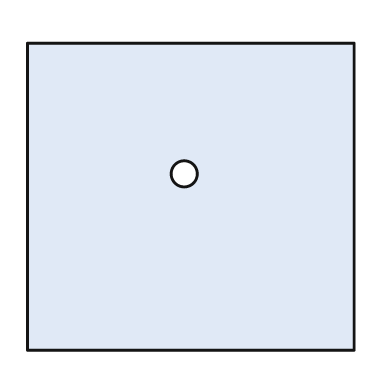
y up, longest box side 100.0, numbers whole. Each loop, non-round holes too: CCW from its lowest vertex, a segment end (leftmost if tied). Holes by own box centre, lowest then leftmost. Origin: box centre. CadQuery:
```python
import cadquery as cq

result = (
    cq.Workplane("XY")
    .moveTo(-50.0, -47.0)
    .lineTo(50.0, -47.0)
    .lineTo(50.0, 47.0)
    .lineTo(-50.0, 47.0)
    .close()
    .moveTo(-2.0, 7.0)
    .circle(4.0)
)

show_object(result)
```